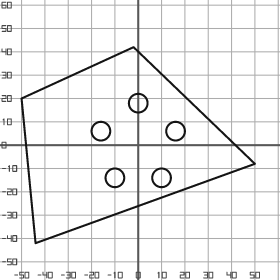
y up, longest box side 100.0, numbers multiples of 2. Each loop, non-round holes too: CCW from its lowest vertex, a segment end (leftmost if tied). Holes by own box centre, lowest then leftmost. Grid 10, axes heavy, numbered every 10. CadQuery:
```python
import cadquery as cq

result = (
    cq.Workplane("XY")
    .moveTo(-44.0, -42.0)
    .lineTo(50.0, -8.0)
    .lineTo(-2.0, 42.0)
    .lineTo(-50.0, 20.0)
    .close()
    .moveTo(-10.0, -14.0)
    .circle(4.0)
    .moveTo(10.0, -14.0)
    .circle(4.0)
    .moveTo(-16.0, 6.0)
    .circle(4.0)
    .moveTo(16.0, 6.0)
    .circle(4.0)
    .moveTo(0.0, 18.0)
    .circle(4.0)
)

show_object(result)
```